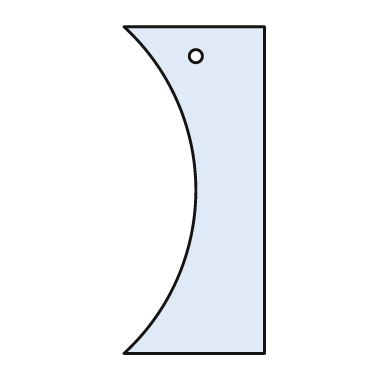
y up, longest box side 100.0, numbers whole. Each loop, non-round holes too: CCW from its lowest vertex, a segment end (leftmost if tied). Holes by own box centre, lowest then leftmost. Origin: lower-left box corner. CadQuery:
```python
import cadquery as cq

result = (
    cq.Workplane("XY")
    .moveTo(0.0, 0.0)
    .lineTo(43.0, 0.0)
    .lineTo(43.0, 100.0)
    .lineTo(0.0, 100.0)
    .threePointArc((22.0, 50.0), (0.0, 0.0))
    .close()
    .moveTo(22.0, 91.0)
    .circle(2.0)
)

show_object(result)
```